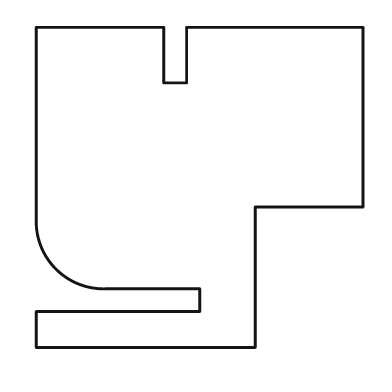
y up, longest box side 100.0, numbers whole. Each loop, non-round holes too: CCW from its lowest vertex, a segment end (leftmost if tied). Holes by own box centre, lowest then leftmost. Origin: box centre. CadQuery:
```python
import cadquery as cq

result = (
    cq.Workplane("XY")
    .moveTo(-50.0, -49.0)
    .lineTo(17.0, -49.0)
    .lineTo(17.0, -6.0)
    .lineTo(50.0, -6.0)
    .lineTo(50.0, 49.0)
    .lineTo(-4.0, 49.0)
    .lineTo(-4.0, 32.0)
    .lineTo(-11.0, 32.0)
    .lineTo(-11.0, 49.0)
    .lineTo(-50.0, 49.0)
    .lineTo(-50.0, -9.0)
    .threePointArc((-44.0, -25.0), (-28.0, -31.0))
    .lineTo(0.0, -31.0)
    .lineTo(0.0, -38.0)
    .lineTo(-50.0, -38.0)
    .close()
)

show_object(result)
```